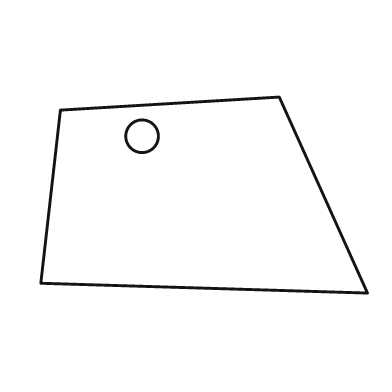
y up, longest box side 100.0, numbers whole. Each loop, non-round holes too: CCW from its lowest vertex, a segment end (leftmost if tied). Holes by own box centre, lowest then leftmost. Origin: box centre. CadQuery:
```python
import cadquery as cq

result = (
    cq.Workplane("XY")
    .moveTo(50.0, -30.0)
    .lineTo(23.0, 30.0)
    .lineTo(-44.0, 26.0)
    .lineTo(-50.0, -27.0)
    .close()
    .moveTo(-19.0, 18.0)
    .circle(5.0)
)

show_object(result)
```